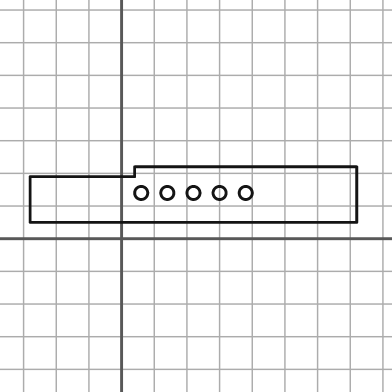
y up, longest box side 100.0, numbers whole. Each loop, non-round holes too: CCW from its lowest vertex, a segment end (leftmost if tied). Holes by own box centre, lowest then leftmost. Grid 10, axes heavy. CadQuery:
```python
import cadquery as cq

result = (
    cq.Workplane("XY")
    .moveTo(-28.0, 5.0)
    .lineTo(72.0, 5.0)
    .lineTo(72.0, 22.0)
    .lineTo(4.0, 22.0)
    .lineTo(4.0, 19.0)
    .lineTo(-28.0, 19.0)
    .close()
    .moveTo(6.0, 14.0)
    .circle(2.0)
    .moveTo(14.0, 14.0)
    .circle(2.0)
    .moveTo(22.0, 14.0)
    .circle(2.0)
    .moveTo(30.0, 14.0)
    .circle(2.0)
    .moveTo(38.0, 14.0)
    .circle(2.0)
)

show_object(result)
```